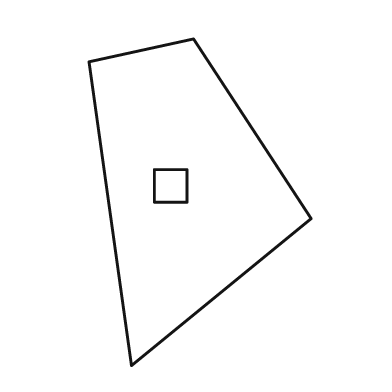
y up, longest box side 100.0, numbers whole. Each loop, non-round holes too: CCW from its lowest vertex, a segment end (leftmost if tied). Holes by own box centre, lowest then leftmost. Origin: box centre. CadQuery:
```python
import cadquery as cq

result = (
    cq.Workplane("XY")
    .moveTo(-21.0, -50.0)
    .lineTo(34.0, -5.0)
    .lineTo(-2.0, 50.0)
    .lineTo(-34.0, 43.0)
    .close()
    .moveTo(-14.0, 0.0)
    .lineTo(-4.0, 0.0)
    .lineTo(-4.0, 10.0)
    .lineTo(-14.0, 10.0)
    .close()
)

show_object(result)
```